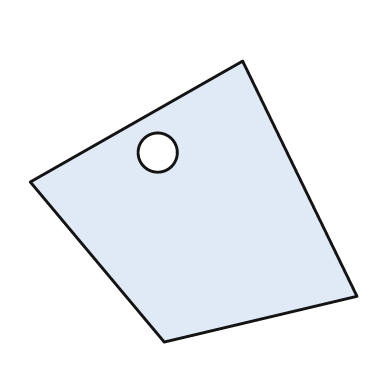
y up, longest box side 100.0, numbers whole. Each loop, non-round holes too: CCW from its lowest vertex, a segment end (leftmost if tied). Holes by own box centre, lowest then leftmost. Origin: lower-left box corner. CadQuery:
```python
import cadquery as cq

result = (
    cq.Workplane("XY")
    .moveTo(41.0, 0.0)
    .lineTo(100.0, 14.0)
    .lineTo(65.0, 86.0)
    .lineTo(0.0, 49.0)
    .close()
    .moveTo(39.0, 58.0)
    .circle(6.0)
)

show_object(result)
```